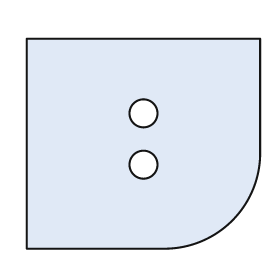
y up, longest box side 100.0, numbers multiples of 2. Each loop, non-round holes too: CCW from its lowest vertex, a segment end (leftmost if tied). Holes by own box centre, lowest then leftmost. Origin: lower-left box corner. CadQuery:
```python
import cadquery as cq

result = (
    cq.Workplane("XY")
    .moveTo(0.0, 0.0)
    .lineTo(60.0, 0.0)
    .threePointArc((88.0, 12.0), (100.0, 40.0))
    .lineTo(100.0, 90.0)
    .lineTo(0.0, 90.0)
    .close()
    .moveTo(50.0, 36.0)
    .circle(6.0)
    .moveTo(50.0, 58.0)
    .circle(6.0)
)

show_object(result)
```